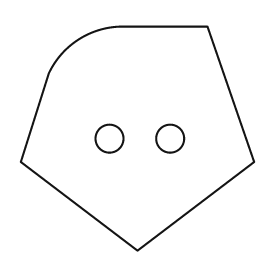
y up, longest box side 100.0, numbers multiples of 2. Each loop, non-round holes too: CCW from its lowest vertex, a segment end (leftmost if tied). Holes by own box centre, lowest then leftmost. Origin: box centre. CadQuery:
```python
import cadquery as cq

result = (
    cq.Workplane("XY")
    .moveTo(0.0, -48.0)
    .lineTo(50.0, -10.0)
    .lineTo(30.0, 48.0)
    .lineTo(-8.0, 48.0)
    .threePointArc((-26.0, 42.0), (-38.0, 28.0))
    .lineTo(-50.0, -10.0)
    .close()
    .moveTo(-12.0, 0.0)
    .circle(6.0)
    .moveTo(14.0, 0.0)
    .circle(6.0)
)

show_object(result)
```